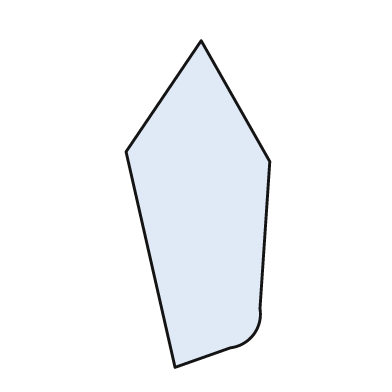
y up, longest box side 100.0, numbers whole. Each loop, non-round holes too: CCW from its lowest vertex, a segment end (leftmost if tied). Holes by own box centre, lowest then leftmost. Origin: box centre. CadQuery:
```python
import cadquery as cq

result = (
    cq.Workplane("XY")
    .moveTo(-7.0, -50.0)
    .lineTo(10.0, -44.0)
    .threePointArc((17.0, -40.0), (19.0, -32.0))
    .lineTo(22.0, 13.0)
    .lineTo(1.0, 50.0)
    .lineTo(-22.0, 16.0)
    .close()
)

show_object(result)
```